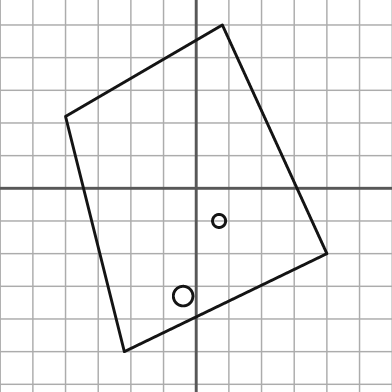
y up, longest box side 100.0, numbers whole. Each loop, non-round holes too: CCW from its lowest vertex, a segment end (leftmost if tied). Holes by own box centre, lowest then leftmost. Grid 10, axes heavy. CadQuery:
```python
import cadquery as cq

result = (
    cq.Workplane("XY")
    .moveTo(-22.0, -50.0)
    .lineTo(40.0, -20.0)
    .lineTo(8.0, 50.0)
    .lineTo(-40.0, 22.0)
    .close()
    .moveTo(-4.0, -33.0)
    .circle(3.0)
    .moveTo(7.0, -10.0)
    .circle(2.0)
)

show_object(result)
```